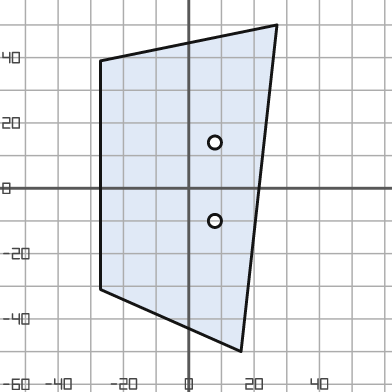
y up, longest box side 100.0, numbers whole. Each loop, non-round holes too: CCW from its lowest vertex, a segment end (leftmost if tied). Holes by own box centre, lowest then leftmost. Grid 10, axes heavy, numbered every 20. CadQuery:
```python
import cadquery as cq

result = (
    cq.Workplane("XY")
    .moveTo(16.0, -50.0)
    .lineTo(27.0, 50.0)
    .lineTo(-27.0, 39.0)
    .lineTo(-27.0, -31.0)
    .close()
    .moveTo(8.0, -10.0)
    .circle(2.0)
    .moveTo(8.0, 14.0)
    .circle(2.0)
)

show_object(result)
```